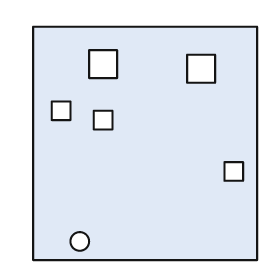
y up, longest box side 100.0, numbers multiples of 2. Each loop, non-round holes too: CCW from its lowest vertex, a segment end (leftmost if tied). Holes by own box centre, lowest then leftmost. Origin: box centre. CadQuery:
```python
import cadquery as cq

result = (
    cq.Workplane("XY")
    .moveTo(-48.0, -50.0)
    .lineTo(48.0, -50.0)
    .lineTo(48.0, 50.0)
    .lineTo(-48.0, 50.0)
    .close()
    .moveTo(-28.0, -42.0)
    .circle(4.0)
    .moveTo(34.0, -16.0)
    .lineTo(42.0, -16.0)
    .lineTo(42.0, -8.0)
    .lineTo(34.0, -8.0)
    .close()
    .moveTo(-22.0, 6.0)
    .lineTo(-14.0, 6.0)
    .lineTo(-14.0, 14.0)
    .lineTo(-22.0, 14.0)
    .close()
    .moveTo(-40.0, 10.0)
    .lineTo(-32.0, 10.0)
    .lineTo(-32.0, 18.0)
    .lineTo(-40.0, 18.0)
    .close()
    .moveTo(18.0, 26.0)
    .lineTo(30.0, 26.0)
    .lineTo(30.0, 38.0)
    .lineTo(18.0, 38.0)
    .close()
    .moveTo(-24.0, 28.0)
    .lineTo(-12.0, 28.0)
    .lineTo(-12.0, 40.0)
    .lineTo(-24.0, 40.0)
    .close()
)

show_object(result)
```